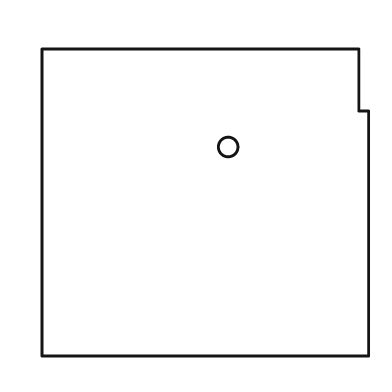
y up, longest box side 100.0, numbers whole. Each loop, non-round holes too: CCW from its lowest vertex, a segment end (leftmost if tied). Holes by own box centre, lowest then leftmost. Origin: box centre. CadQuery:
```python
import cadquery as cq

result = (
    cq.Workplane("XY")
    .moveTo(-50.0, -47.0)
    .lineTo(50.0, -47.0)
    .lineTo(50.0, 28.0)
    .lineTo(47.0, 28.0)
    .lineTo(47.0, 47.0)
    .lineTo(-50.0, 47.0)
    .close()
    .moveTo(7.0, 17.0)
    .circle(3.0)
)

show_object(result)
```